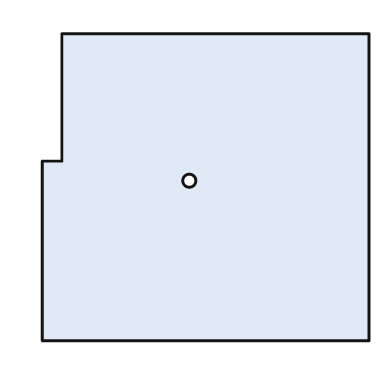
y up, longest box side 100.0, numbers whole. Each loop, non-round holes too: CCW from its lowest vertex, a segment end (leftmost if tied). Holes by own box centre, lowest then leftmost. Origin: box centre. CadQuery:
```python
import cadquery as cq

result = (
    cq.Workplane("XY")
    .moveTo(-50.0, -47.0)
    .lineTo(50.0, -47.0)
    .lineTo(50.0, 47.0)
    .lineTo(-44.0, 47.0)
    .lineTo(-44.0, 8.0)
    .lineTo(-50.0, 8.0)
    .close()
    .moveTo(-5.0, 2.0)
    .circle(2.0)
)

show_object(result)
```